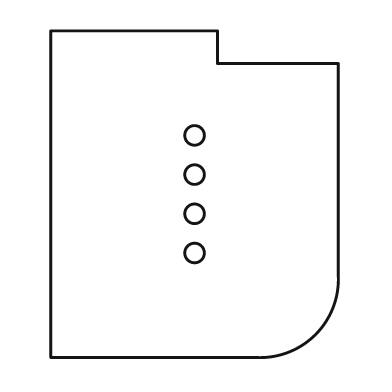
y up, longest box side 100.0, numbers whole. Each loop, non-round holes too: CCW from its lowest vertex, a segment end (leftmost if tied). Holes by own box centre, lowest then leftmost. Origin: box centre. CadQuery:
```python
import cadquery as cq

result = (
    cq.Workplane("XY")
    .moveTo(-44.0, -50.0)
    .lineTo(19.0, -50.0)
    .threePointArc((37.0, -43.0), (44.0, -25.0))
    .lineTo(44.0, 40.0)
    .lineTo(7.0, 40.0)
    .lineTo(7.0, 50.0)
    .lineTo(-44.0, 50.0)
    .close()
    .moveTo(0.0, -18.0)
    .circle(3.0)
    .moveTo(0.0, -6.0)
    .circle(3.0)
    .moveTo(0.0, 6.0)
    .circle(3.0)
    .moveTo(0.0, 18.0)
    .circle(3.0)
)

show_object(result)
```